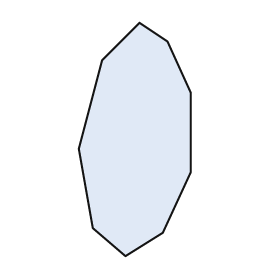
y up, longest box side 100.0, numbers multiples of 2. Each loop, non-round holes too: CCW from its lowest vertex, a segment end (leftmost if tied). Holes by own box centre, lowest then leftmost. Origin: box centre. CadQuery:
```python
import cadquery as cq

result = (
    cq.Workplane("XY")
    .moveTo(-4.0, -50.0)
    .lineTo(12.0, -40.0)
    .lineTo(24.0, -14.0)
    .lineTo(24.0, 20.0)
    .lineTo(14.0, 42.0)
    .lineTo(2.0, 50.0)
    .lineTo(-14.0, 34.0)
    .lineTo(-24.0, -4.0)
    .lineTo(-18.0, -38.0)
    .close()
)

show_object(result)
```